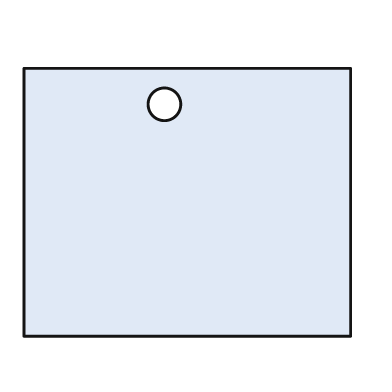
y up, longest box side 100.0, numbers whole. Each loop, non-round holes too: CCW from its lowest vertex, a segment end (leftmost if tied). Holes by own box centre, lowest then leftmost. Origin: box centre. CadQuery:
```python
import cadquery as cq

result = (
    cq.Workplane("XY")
    .moveTo(-50.0, -41.0)
    .lineTo(50.0, -41.0)
    .lineTo(50.0, 41.0)
    .lineTo(-50.0, 41.0)
    .close()
    .moveTo(-7.0, 30.0)
    .circle(5.0)
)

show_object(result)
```